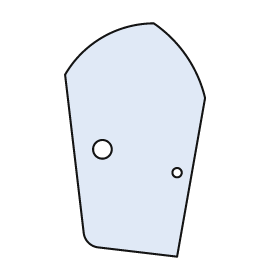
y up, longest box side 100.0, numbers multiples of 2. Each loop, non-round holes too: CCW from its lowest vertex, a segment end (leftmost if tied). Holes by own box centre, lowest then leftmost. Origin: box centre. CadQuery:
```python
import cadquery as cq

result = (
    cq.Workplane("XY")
    .moveTo(18.0, -50.0)
    .lineTo(30.0, 18.0)
    .threePointArc((22.0, 36.0), (8.0, 50.0))
    .threePointArc((-14.0, 44.0), (-30.0, 28.0))
    .lineTo(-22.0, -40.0)
    .threePointArc((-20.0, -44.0), (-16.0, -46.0))
    .close()
    .moveTo(18.0, -14.0)
    .circle(2.0)
    .moveTo(-14.0, -4.0)
    .circle(4.0)
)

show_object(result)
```